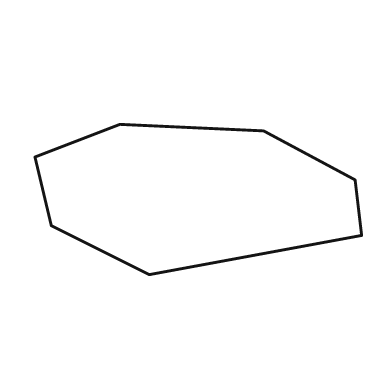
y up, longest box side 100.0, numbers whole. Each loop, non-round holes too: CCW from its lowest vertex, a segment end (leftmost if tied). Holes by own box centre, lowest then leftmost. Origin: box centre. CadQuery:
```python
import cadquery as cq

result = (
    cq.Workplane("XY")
    .moveTo(-15.0, -23.0)
    .lineTo(50.0, -11.0)
    .lineTo(48.0, 6.0)
    .lineTo(20.0, 21.0)
    .lineTo(-24.0, 23.0)
    .lineTo(-50.0, 13.0)
    .lineTo(-45.0, -8.0)
    .close()
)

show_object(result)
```